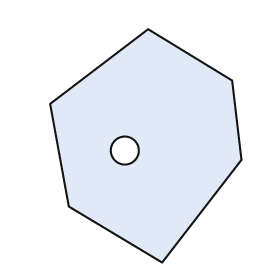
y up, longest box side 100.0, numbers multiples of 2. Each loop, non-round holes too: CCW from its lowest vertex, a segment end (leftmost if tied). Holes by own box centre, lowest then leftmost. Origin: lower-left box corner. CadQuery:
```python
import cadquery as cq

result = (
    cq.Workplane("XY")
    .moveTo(48.0, 0.0)
    .lineTo(82.0, 44.0)
    .lineTo(78.0, 78.0)
    .lineTo(42.0, 100.0)
    .lineTo(0.0, 68.0)
    .lineTo(8.0, 24.0)
    .close()
    .moveTo(32.0, 48.0)
    .circle(6.0)
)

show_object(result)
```